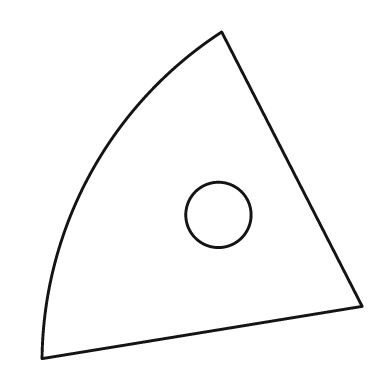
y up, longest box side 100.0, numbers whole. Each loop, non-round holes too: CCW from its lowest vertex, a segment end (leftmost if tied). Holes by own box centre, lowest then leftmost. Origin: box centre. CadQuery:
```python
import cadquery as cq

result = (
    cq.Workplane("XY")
    .moveTo(-49.0, -50.0)
    .lineTo(49.0, -34.0)
    .lineTo(6.0, 50.0)
    .threePointArc((-34.0, 7.0), (-49.0, -50.0))
    .close()
    .moveTo(5.0, -6.0)
    .circle(10.0)
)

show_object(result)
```